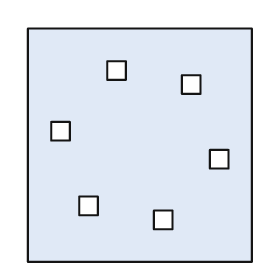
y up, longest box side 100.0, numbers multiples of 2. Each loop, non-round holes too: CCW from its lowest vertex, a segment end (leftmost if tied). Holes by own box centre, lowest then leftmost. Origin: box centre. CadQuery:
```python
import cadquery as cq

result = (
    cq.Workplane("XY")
    .moveTo(-48.0, -50.0)
    .lineTo(48.0, -50.0)
    .lineTo(48.0, 50.0)
    .lineTo(-48.0, 50.0)
    .close()
    .moveTo(6.0, -36.0)
    .lineTo(14.0, -36.0)
    .lineTo(14.0, -28.0)
    .lineTo(6.0, -28.0)
    .close()
    .moveTo(-26.0, -30.0)
    .lineTo(-18.0, -30.0)
    .lineTo(-18.0, -22.0)
    .lineTo(-26.0, -22.0)
    .close()
    .moveTo(30.0, -10.0)
    .lineTo(38.0, -10.0)
    .lineTo(38.0, -2.0)
    .lineTo(30.0, -2.0)
    .close()
    .moveTo(-38.0, 2.0)
    .lineTo(-30.0, 2.0)
    .lineTo(-30.0, 10.0)
    .lineTo(-38.0, 10.0)
    .close()
    .moveTo(18.0, 22.0)
    .lineTo(26.0, 22.0)
    .lineTo(26.0, 30.0)
    .lineTo(18.0, 30.0)
    .close()
    .moveTo(-14.0, 28.0)
    .lineTo(-6.0, 28.0)
    .lineTo(-6.0, 36.0)
    .lineTo(-14.0, 36.0)
    .close()
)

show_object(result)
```